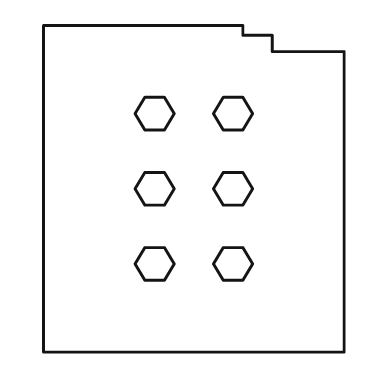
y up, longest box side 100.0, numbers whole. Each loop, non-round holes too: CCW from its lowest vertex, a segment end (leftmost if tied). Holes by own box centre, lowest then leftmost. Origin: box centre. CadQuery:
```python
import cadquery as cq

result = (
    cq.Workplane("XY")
    .moveTo(-46.0, -50.0)
    .lineTo(46.0, -50.0)
    .lineTo(46.0, 42.0)
    .lineTo(24.0, 42.0)
    .lineTo(24.0, 47.0)
    .lineTo(15.0, 47.0)
    .lineTo(15.0, 50.0)
    .lineTo(-46.0, 50.0)
    .close()
    .moveTo(-15.0, -28.0)
    .lineTo(-9.0, -28.0)
    .lineTo(-6.0, -23.0)
    .lineTo(-9.0, -18.0)
    .lineTo(-15.0, -18.0)
    .lineTo(-18.0, -23.0)
    .close()
    .moveTo(9.0, -28.0)
    .lineTo(15.0, -28.0)
    .lineTo(18.0, -23.0)
    .lineTo(15.0, -18.0)
    .lineTo(9.0, -18.0)
    .lineTo(6.0, -23.0)
    .close()
    .moveTo(-15.0, -5.0)
    .lineTo(-9.0, -5.0)
    .lineTo(-6.0, 0.0)
    .lineTo(-9.0, 5.0)
    .lineTo(-15.0, 5.0)
    .lineTo(-18.0, 0.0)
    .close()
    .moveTo(9.0, -5.0)
    .lineTo(15.0, -5.0)
    .lineTo(18.0, 0.0)
    .lineTo(15.0, 5.0)
    .lineTo(9.0, 5.0)
    .lineTo(6.0, 0.0)
    .close()
    .moveTo(-15.0, 18.0)
    .lineTo(-9.0, 18.0)
    .lineTo(-6.0, 23.0)
    .lineTo(-9.0, 28.0)
    .lineTo(-15.0, 28.0)
    .lineTo(-18.0, 23.0)
    .close()
    .moveTo(9.0, 18.0)
    .lineTo(15.0, 18.0)
    .lineTo(18.0, 23.0)
    .lineTo(15.0, 28.0)
    .lineTo(9.0, 28.0)
    .lineTo(6.0, 23.0)
    .close()
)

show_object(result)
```